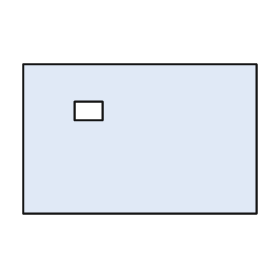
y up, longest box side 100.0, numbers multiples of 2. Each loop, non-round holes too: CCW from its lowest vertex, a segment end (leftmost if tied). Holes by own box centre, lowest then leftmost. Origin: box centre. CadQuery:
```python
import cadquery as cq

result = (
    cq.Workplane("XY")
    .moveTo(-50.0, -32.0)
    .lineTo(50.0, -32.0)
    .lineTo(50.0, 32.0)
    .lineTo(-50.0, 32.0)
    .close()
    .moveTo(-28.0, 8.0)
    .lineTo(-16.0, 8.0)
    .lineTo(-16.0, 16.0)
    .lineTo(-28.0, 16.0)
    .close()
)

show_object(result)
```